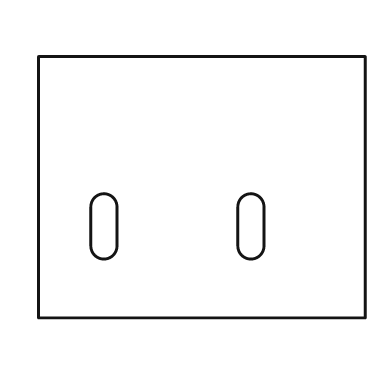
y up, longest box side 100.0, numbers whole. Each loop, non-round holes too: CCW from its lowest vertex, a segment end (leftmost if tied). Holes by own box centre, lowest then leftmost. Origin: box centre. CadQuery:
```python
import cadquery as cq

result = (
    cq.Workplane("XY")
    .moveTo(-50.0, -40.0)
    .lineTo(50.0, -40.0)
    .lineTo(50.0, 40.0)
    .lineTo(-50.0, 40.0)
    .close()
    .moveTo(-34.0, -18.0)
    .threePointArc((-30.0, -22.0), (-26.0, -18.0))
    .lineTo(-26.0, -6.0)
    .threePointArc((-30.0, -2.0), (-34.0, -6.0))
    .close()
    .moveTo(11.0, -18.0)
    .threePointArc((15.0, -22.0), (19.0, -18.0))
    .lineTo(19.0, -6.0)
    .threePointArc((15.0, -2.0), (11.0, -6.0))
    .close()
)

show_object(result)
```